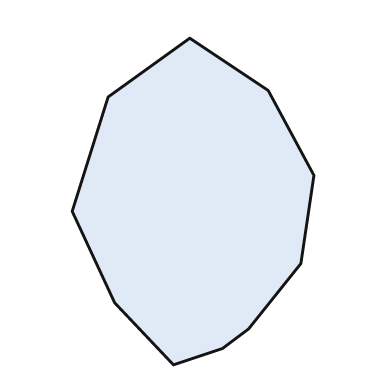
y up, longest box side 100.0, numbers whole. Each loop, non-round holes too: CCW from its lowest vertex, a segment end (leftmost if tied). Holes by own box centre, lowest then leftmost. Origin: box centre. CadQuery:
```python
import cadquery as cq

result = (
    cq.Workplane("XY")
    .moveTo(-6.0, -50.0)
    .lineTo(9.0, -45.0)
    .lineTo(17.0, -39.0)
    .lineTo(33.0, -19.0)
    .lineTo(37.0, 8.0)
    .lineTo(23.0, 34.0)
    .lineTo(-1.0, 50.0)
    .lineTo(-26.0, 32.0)
    .lineTo(-37.0, -3.0)
    .lineTo(-24.0, -31.0)
    .close()
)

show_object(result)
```